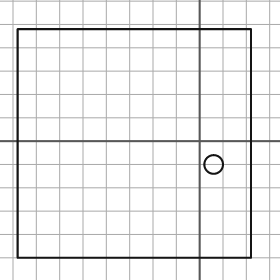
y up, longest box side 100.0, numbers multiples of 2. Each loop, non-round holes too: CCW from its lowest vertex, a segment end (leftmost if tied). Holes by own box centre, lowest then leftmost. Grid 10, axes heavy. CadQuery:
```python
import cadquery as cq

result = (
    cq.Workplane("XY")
    .moveTo(-78.0, -50.0)
    .lineTo(22.0, -50.0)
    .lineTo(22.0, 48.0)
    .lineTo(-78.0, 48.0)
    .close()
    .moveTo(6.0, -10.0)
    .circle(4.0)
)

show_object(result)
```